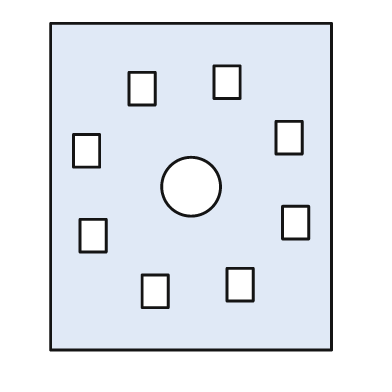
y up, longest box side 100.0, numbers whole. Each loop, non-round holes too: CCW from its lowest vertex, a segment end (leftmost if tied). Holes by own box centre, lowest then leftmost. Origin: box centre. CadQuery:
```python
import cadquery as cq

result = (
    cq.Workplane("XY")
    .moveTo(-43.0, -50.0)
    .lineTo(43.0, -50.0)
    .lineTo(43.0, 50.0)
    .lineTo(-43.0, 50.0)
    .close()
    .moveTo(-15.0, -37.0)
    .lineTo(-7.0, -37.0)
    .lineTo(-7.0, -27.0)
    .lineTo(-15.0, -27.0)
    .close()
    .moveTo(11.0, -35.0)
    .lineTo(19.0, -35.0)
    .lineTo(19.0, -25.0)
    .lineTo(11.0, -25.0)
    .close()
    .moveTo(-34.0, -20.0)
    .lineTo(-26.0, -20.0)
    .lineTo(-26.0, -10.0)
    .lineTo(-34.0, -10.0)
    .close()
    .moveTo(28.0, -16.0)
    .lineTo(36.0, -16.0)
    .lineTo(36.0, -6.0)
    .lineTo(28.0, -6.0)
    .close()
    .moveTo(0.0, 0.0)
    .circle(9.0)
    .moveTo(-36.0, 6.0)
    .lineTo(-28.0, 6.0)
    .lineTo(-28.0, 16.0)
    .lineTo(-36.0, 16.0)
    .close()
    .moveTo(26.0, 10.0)
    .lineTo(34.0, 10.0)
    .lineTo(34.0, 20.0)
    .lineTo(26.0, 20.0)
    .close()
    .moveTo(-19.0, 25.0)
    .lineTo(-11.0, 25.0)
    .lineTo(-11.0, 35.0)
    .lineTo(-19.0, 35.0)
    .close()
    .moveTo(7.0, 27.0)
    .lineTo(15.0, 27.0)
    .lineTo(15.0, 37.0)
    .lineTo(7.0, 37.0)
    .close()
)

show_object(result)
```